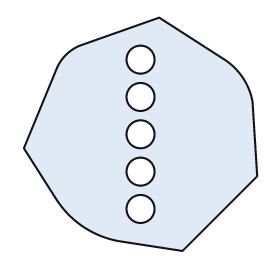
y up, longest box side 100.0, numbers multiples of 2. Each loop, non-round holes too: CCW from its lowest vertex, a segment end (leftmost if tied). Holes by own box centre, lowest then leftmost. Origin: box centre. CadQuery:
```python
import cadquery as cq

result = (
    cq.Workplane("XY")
    .moveTo(18.0, -50.0)
    .lineTo(50.0, -18.0)
    .lineTo(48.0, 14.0)
    .threePointArc((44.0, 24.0), (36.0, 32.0))
    .lineTo(8.0, 50.0)
    .lineTo(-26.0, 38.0)
    .threePointArc((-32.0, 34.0), (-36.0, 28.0))
    .lineTo(-50.0, -6.0)
    .lineTo(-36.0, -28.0)
    .threePointArc((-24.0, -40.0), (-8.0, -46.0))
    .close()
    .moveTo(0.0, -32.0)
    .circle(6.0)
    .moveTo(0.0, -16.0)
    .circle(6.0)
    .moveTo(0.0, 0.0)
    .circle(6.0)
    .moveTo(0.0, 16.0)
    .circle(6.0)
    .moveTo(0.0, 32.0)
    .circle(6.0)
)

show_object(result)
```